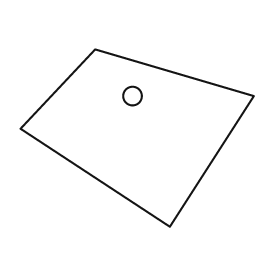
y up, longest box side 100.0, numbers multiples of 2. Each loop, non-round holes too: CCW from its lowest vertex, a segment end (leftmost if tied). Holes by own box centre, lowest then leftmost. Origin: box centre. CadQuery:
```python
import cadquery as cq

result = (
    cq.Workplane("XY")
    .moveTo(14.0, -38.0)
    .lineTo(50.0, 18.0)
    .lineTo(-18.0, 38.0)
    .lineTo(-50.0, 4.0)
    .close()
    .moveTo(-2.0, 18.0)
    .circle(4.0)
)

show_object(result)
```